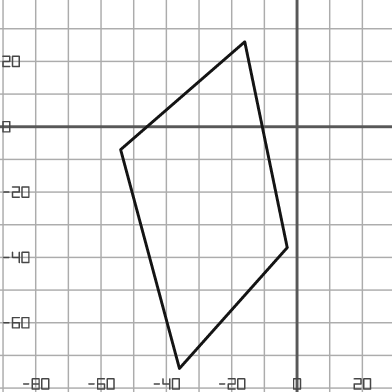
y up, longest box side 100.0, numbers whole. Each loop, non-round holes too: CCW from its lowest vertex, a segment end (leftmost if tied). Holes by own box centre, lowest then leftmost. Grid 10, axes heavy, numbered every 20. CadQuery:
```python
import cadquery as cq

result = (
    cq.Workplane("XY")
    .moveTo(-36.0, -74.0)
    .lineTo(-3.0, -37.0)
    .lineTo(-16.0, 26.0)
    .lineTo(-54.0, -7.0)
    .close()
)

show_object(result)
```